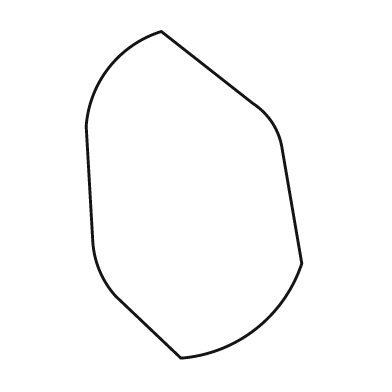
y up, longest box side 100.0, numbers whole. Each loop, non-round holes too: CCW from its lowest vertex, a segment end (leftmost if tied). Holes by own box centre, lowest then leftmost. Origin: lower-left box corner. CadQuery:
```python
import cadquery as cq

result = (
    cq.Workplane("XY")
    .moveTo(29.0, 0.0)
    .threePointArc((52.0, 9.0), (66.0, 29.0))
    .lineTo(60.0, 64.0)
    .threePointArc((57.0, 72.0), (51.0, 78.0))
    .lineTo(23.0, 100.0)
    .threePointArc((7.0, 89.0), (0.0, 71.0))
    .lineTo(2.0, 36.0)
    .threePointArc((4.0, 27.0), (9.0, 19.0))
    .close()
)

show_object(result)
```